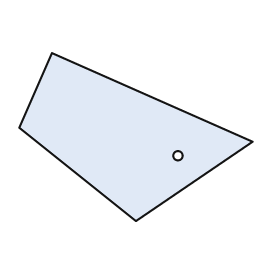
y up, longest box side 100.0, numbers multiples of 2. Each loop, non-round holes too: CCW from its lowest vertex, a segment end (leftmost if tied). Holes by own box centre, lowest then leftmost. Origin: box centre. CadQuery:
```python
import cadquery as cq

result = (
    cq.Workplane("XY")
    .moveTo(0.0, -36.0)
    .lineTo(50.0, -2.0)
    .lineTo(-36.0, 36.0)
    .lineTo(-50.0, 4.0)
    .close()
    .moveTo(18.0, -8.0)
    .circle(2.0)
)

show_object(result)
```